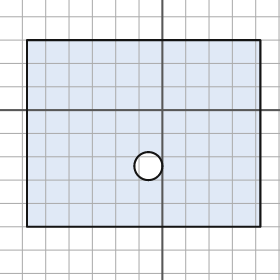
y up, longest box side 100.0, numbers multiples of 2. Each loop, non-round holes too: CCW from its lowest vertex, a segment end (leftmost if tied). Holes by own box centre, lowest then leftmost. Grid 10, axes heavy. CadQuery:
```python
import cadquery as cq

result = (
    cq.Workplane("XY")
    .moveTo(-58.0, -50.0)
    .lineTo(42.0, -50.0)
    .lineTo(42.0, 30.0)
    .lineTo(-58.0, 30.0)
    .close()
    .moveTo(-6.0, -24.0)
    .circle(6.0)
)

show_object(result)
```